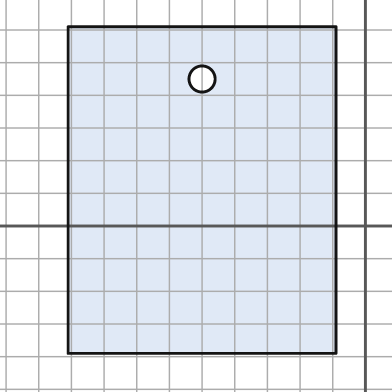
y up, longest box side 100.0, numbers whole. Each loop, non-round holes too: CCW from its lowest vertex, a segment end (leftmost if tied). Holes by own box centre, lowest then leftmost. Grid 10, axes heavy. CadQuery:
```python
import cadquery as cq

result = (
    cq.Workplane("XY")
    .moveTo(-91.0, -39.0)
    .lineTo(-9.0, -39.0)
    .lineTo(-9.0, 61.0)
    .lineTo(-91.0, 61.0)
    .close()
    .moveTo(-50.0, 45.0)
    .circle(4.0)
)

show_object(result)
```